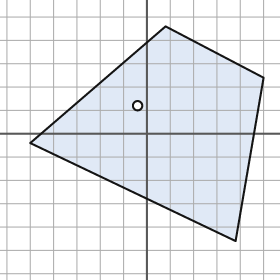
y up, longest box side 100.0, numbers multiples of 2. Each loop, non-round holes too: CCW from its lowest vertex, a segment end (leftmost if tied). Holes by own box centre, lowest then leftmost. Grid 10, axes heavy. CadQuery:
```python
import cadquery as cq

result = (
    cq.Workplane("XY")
    .moveTo(38.0, -46.0)
    .lineTo(50.0, 24.0)
    .lineTo(8.0, 46.0)
    .lineTo(-50.0, -4.0)
    .close()
    .moveTo(-4.0, 12.0)
    .circle(2.0)
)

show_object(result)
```